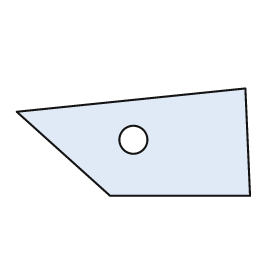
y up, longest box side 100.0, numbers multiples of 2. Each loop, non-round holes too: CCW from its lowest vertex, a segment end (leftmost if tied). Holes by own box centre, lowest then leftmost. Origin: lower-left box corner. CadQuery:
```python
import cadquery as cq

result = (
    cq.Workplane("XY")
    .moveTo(40.0, 0.0)
    .lineTo(100.0, 0.0)
    .lineTo(98.0, 46.0)
    .lineTo(0.0, 36.0)
    .close()
    .moveTo(50.0, 24.0)
    .circle(6.0)
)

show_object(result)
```